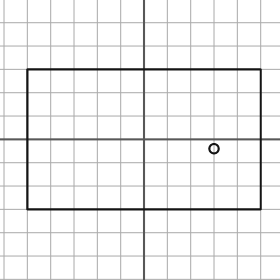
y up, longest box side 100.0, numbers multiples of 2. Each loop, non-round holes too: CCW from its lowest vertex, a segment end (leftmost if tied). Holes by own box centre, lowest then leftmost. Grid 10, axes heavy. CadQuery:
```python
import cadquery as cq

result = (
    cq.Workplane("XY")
    .moveTo(-50.0, -30.0)
    .lineTo(50.0, -30.0)
    .lineTo(50.0, 30.0)
    .lineTo(-50.0, 30.0)
    .close()
    .moveTo(30.0, -4.0)
    .circle(2.0)
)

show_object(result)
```